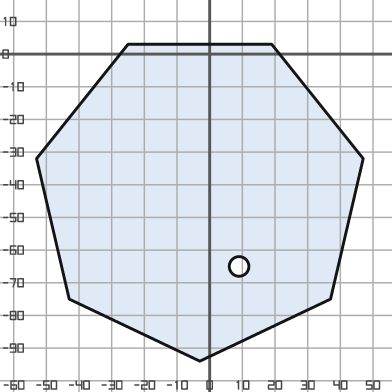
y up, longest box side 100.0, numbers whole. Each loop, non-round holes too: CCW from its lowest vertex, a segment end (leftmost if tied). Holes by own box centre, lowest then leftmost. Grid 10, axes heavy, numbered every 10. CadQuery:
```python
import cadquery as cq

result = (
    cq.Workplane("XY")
    .moveTo(-3.0, -94.0)
    .lineTo(37.0, -75.0)
    .lineTo(47.0, -32.0)
    .lineTo(19.0, 3.0)
    .lineTo(-25.0, 3.0)
    .lineTo(-53.0, -32.0)
    .lineTo(-43.0, -75.0)
    .close()
    .moveTo(9.0, -65.0)
    .circle(3.0)
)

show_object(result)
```